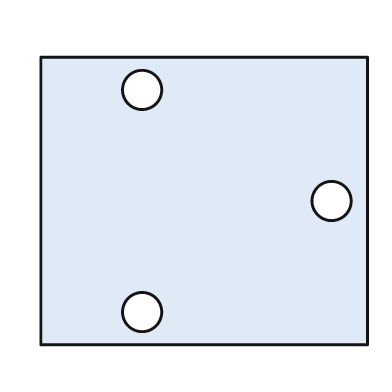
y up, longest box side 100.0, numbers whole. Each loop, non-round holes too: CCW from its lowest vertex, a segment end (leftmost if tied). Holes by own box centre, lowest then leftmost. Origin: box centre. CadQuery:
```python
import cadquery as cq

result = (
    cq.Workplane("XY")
    .moveTo(-50.0, -44.0)
    .lineTo(50.0, -44.0)
    .lineTo(50.0, 44.0)
    .lineTo(-50.0, 44.0)
    .close()
    .moveTo(-19.0, -34.0)
    .circle(6.0)
    .moveTo(39.0, 0.0)
    .circle(6.0)
    .moveTo(-19.0, 34.0)
    .circle(6.0)
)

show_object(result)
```